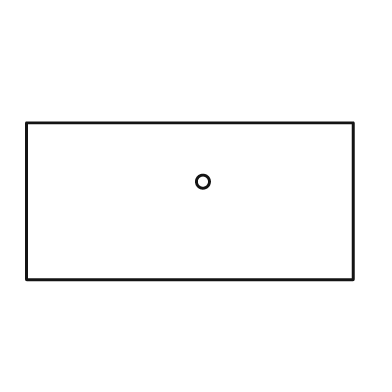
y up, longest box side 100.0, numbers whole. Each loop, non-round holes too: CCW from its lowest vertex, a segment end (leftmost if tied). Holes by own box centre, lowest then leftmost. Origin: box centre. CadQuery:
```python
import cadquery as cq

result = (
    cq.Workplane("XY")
    .moveTo(-50.0, -24.0)
    .lineTo(50.0, -24.0)
    .lineTo(50.0, 24.0)
    .lineTo(-50.0, 24.0)
    .close()
    .moveTo(4.0, 6.0)
    .circle(2.0)
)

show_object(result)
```